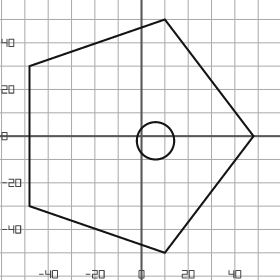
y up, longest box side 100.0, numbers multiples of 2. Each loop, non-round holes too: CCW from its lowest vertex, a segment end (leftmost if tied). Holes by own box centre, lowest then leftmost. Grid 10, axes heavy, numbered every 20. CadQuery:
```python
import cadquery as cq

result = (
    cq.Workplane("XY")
    .moveTo(10.0, -50.0)
    .lineTo(48.0, 0.0)
    .lineTo(10.0, 50.0)
    .lineTo(-48.0, 30.0)
    .lineTo(-48.0, -30.0)
    .close()
    .moveTo(6.0, -2.0)
    .circle(8.0)
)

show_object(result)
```